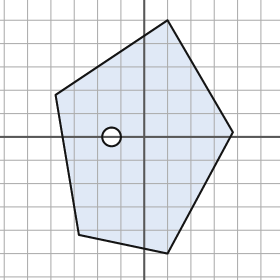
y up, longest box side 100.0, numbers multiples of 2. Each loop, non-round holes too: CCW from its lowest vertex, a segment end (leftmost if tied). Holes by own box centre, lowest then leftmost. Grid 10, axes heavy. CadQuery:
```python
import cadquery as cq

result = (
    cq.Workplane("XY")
    .moveTo(10.0, -50.0)
    .lineTo(38.0, 2.0)
    .lineTo(10.0, 50.0)
    .lineTo(-38.0, 18.0)
    .lineTo(-28.0, -42.0)
    .close()
    .moveTo(-14.0, 0.0)
    .circle(4.0)
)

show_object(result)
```